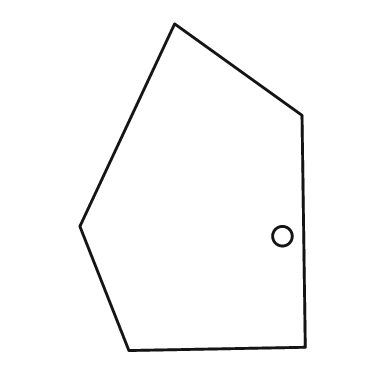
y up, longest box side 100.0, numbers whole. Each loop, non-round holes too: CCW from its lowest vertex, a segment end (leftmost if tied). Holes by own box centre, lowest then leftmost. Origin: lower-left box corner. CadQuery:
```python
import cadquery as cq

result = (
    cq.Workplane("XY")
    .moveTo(15.0, 0.0)
    .lineTo(69.0, 1.0)
    .lineTo(68.0, 72.0)
    .lineTo(29.0, 100.0)
    .lineTo(0.0, 38.0)
    .close()
    .moveTo(62.0, 35.0)
    .circle(3.0)
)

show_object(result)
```